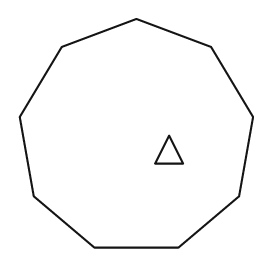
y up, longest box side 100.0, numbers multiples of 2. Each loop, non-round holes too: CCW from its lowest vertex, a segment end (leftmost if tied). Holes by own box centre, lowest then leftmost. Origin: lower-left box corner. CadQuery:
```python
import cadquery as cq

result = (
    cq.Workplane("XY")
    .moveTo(32.0, 0.0)
    .lineTo(68.0, 0.0)
    .lineTo(94.0, 22.0)
    .lineTo(100.0, 56.0)
    .lineTo(82.0, 86.0)
    .lineTo(50.0, 98.0)
    .lineTo(18.0, 86.0)
    .lineTo(0.0, 56.0)
    .lineTo(6.0, 22.0)
    .close()
    .moveTo(58.0, 36.0)
    .lineTo(70.0, 36.0)
    .lineTo(64.0, 48.0)
    .close()
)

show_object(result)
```